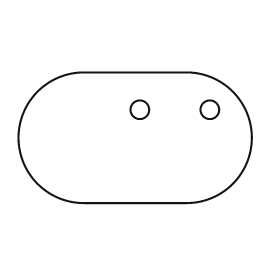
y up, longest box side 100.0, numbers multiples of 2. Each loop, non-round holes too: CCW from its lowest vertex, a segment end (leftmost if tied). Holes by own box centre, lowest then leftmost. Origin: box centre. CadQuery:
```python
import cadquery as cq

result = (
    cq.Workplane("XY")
    .moveTo(-22.0, -28.0)
    .lineTo(22.0, -28.0)
    .threePointArc((50.0, 0.0), (22.0, 28.0))
    .lineTo(-22.0, 28.0)
    .threePointArc((-50.0, 0.0), (-22.0, -28.0))
    .close()
    .moveTo(2.0, 12.0)
    .circle(4.0)
    .moveTo(32.0, 12.0)
    .circle(4.0)
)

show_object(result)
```